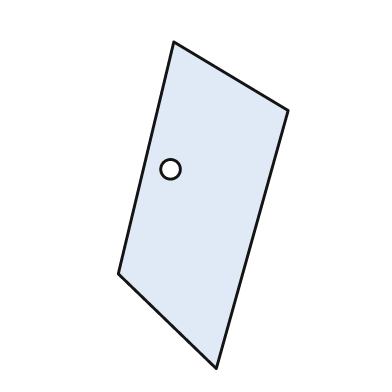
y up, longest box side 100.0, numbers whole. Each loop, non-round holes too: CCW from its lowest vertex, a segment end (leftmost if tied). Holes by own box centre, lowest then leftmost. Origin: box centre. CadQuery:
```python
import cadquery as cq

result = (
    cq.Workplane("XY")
    .moveTo(4.0, -50.0)
    .lineTo(26.0, 29.0)
    .lineTo(-9.0, 50.0)
    .lineTo(-26.0, -21.0)
    .close()
    .moveTo(-10.0, 11.0)
    .circle(3.0)
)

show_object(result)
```